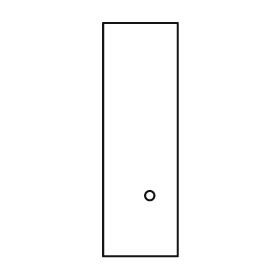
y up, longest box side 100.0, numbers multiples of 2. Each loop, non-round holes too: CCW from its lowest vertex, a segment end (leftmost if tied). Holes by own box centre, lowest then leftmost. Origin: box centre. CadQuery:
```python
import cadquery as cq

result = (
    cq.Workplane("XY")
    .moveTo(-16.0, -50.0)
    .lineTo(16.0, -50.0)
    .lineTo(16.0, 50.0)
    .lineTo(-16.0, 50.0)
    .close()
    .moveTo(4.0, -24.0)
    .circle(2.0)
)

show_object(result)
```